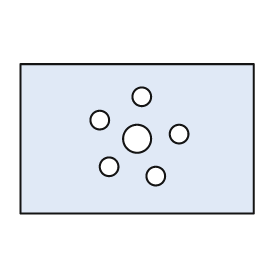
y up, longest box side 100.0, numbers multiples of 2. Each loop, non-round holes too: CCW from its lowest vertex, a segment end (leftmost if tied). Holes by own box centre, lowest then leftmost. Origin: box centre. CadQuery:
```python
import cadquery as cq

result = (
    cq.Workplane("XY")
    .moveTo(-50.0, -32.0)
    .lineTo(50.0, -32.0)
    .lineTo(50.0, 32.0)
    .lineTo(-50.0, 32.0)
    .close()
    .moveTo(8.0, -16.0)
    .circle(4.0)
    .moveTo(-12.0, -12.0)
    .circle(4.0)
    .moveTo(0.0, 0.0)
    .circle(6.0)
    .moveTo(18.0, 2.0)
    .circle(4.0)
    .moveTo(-16.0, 8.0)
    .circle(4.0)
    .moveTo(2.0, 18.0)
    .circle(4.0)
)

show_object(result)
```